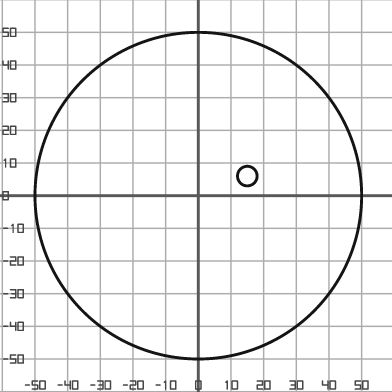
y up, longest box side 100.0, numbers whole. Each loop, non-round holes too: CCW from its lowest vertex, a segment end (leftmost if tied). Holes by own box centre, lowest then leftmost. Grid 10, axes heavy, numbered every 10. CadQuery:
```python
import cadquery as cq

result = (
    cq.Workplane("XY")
    .moveTo(0.0, 0.0)
    .circle(50.0)
    .moveTo(15.0, 6.0)
    .circle(3.0)
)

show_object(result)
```